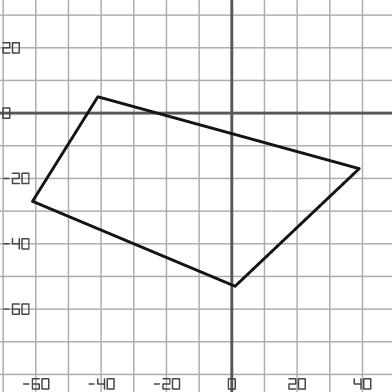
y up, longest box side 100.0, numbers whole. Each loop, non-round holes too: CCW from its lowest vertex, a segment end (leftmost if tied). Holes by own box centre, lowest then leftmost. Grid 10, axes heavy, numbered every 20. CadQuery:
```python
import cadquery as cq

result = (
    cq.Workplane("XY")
    .moveTo(1.0, -53.0)
    .lineTo(39.0, -17.0)
    .lineTo(-41.0, 5.0)
    .lineTo(-61.0, -27.0)
    .close()
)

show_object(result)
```